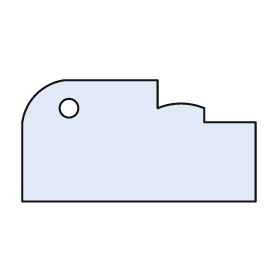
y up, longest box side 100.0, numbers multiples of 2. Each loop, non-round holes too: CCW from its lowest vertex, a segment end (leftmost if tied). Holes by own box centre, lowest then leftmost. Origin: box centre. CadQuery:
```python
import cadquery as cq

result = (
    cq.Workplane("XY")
    .moveTo(-50.0, -26.0)
    .lineTo(50.0, -26.0)
    .lineTo(50.0, 8.0)
    .lineTo(28.0, 8.0)
    .lineTo(28.0, 14.0)
    .threePointArc((18.0, 16.0), (8.0, 14.0))
    .lineTo(8.0, 26.0)
    .lineTo(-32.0, 26.0)
    .threePointArc((-44.0, 20.0), (-50.0, 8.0))
    .close()
    .moveTo(-30.0, 14.0)
    .circle(4.0)
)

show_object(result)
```